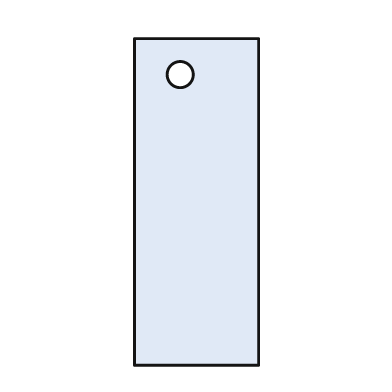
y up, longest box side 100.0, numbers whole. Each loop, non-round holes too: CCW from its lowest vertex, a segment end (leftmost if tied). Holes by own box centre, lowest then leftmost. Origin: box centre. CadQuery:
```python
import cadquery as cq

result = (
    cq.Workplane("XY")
    .moveTo(-19.0, -50.0)
    .lineTo(19.0, -50.0)
    .lineTo(19.0, 50.0)
    .lineTo(-19.0, 50.0)
    .close()
    .moveTo(-5.0, 39.0)
    .circle(4.0)
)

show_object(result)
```